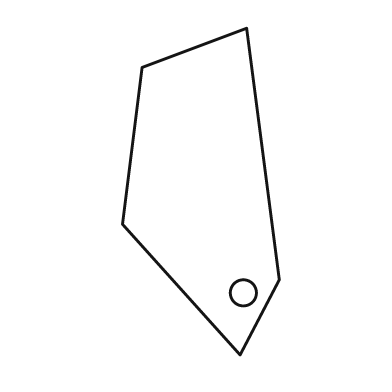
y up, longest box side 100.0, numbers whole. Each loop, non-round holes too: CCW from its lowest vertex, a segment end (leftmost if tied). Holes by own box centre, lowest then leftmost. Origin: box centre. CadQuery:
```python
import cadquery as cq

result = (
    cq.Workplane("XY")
    .moveTo(12.0, -50.0)
    .lineTo(24.0, -27.0)
    .lineTo(14.0, 50.0)
    .lineTo(-18.0, 38.0)
    .lineTo(-24.0, -10.0)
    .close()
    .moveTo(13.0, -31.0)
    .circle(4.0)
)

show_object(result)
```